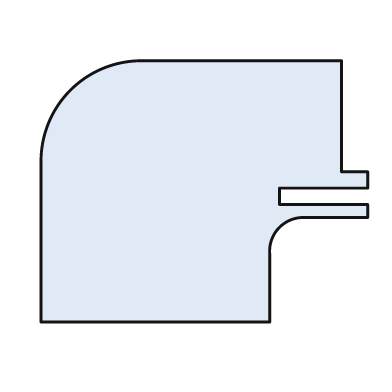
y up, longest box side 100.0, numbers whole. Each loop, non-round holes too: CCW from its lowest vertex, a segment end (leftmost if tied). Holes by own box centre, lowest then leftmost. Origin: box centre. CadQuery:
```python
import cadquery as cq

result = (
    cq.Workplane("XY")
    .moveTo(-50.0, -40.0)
    .lineTo(20.0, -40.0)
    .lineTo(20.0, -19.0)
    .threePointArc((23.0, -11.0), (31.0, -8.0))
    .lineTo(50.0, -8.0)
    .lineTo(50.0, -4.0)
    .lineTo(23.0, -4.0)
    .lineTo(23.0, 1.0)
    .lineTo(50.0, 1.0)
    .lineTo(50.0, 6.0)
    .lineTo(42.0, 6.0)
    .lineTo(42.0, 40.0)
    .lineTo(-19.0, 40.0)
    .threePointArc((-41.0, 31.0), (-50.0, 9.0))
    .close()
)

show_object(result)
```